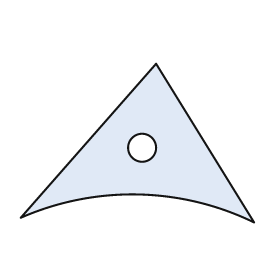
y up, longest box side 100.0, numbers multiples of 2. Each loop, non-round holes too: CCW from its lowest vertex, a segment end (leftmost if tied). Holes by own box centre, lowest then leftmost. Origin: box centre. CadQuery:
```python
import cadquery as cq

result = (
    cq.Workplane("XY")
    .moveTo(50.0, -34.0)
    .lineTo(8.0, 34.0)
    .lineTo(-50.0, -32.0)
    .threePointArc((0.0, -22.0), (50.0, -34.0))
    .close()
    .moveTo(2.0, -2.0)
    .circle(6.0)
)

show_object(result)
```